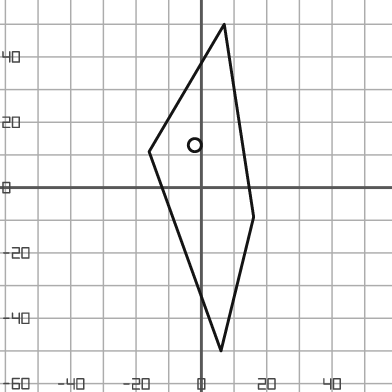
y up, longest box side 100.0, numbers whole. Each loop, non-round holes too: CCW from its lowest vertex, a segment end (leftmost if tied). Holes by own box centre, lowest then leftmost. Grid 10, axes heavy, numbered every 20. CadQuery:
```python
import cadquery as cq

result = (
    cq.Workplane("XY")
    .moveTo(6.0, -50.0)
    .lineTo(16.0, -9.0)
    .lineTo(7.0, 50.0)
    .lineTo(-16.0, 11.0)
    .close()
    .moveTo(-2.0, 13.0)
    .circle(2.0)
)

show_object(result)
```